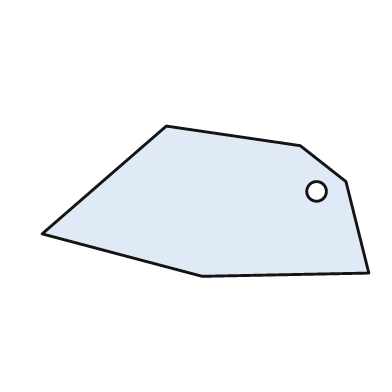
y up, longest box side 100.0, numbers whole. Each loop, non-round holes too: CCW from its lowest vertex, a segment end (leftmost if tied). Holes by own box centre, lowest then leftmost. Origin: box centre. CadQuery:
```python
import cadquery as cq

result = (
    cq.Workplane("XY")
    .moveTo(-1.0, -23.0)
    .lineTo(50.0, -22.0)
    .lineTo(43.0, 6.0)
    .lineTo(29.0, 17.0)
    .lineTo(-12.0, 23.0)
    .lineTo(-50.0, -10.0)
    .close()
    .moveTo(34.0, 3.0)
    .circle(3.0)
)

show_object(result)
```